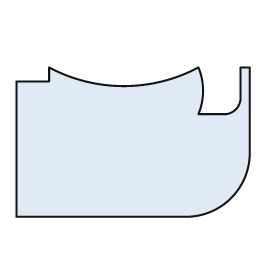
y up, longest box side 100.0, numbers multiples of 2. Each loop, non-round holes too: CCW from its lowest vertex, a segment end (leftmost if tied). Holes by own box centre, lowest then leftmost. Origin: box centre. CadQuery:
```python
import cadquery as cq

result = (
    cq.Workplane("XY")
    .moveTo(-50.0, -32.0)
    .lineTo(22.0, -32.0)
    .threePointArc((42.0, -24.0), (50.0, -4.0))
    .lineTo(50.0, 32.0)
    .lineTo(46.0, 32.0)
    .lineTo(46.0, 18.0)
    .threePointArc((44.0, 14.0), (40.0, 12.0))
    .lineTo(28.0, 12.0)
    .threePointArc((30.0, 22.0), (28.0, 32.0))
    .threePointArc((-4.0, 24.0), (-36.0, 32.0))
    .lineTo(-36.0, 26.0)
    .lineTo(-50.0, 26.0)
    .close()
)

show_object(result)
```